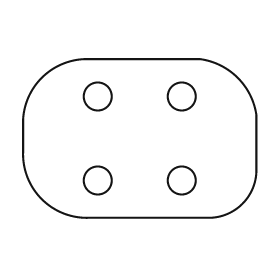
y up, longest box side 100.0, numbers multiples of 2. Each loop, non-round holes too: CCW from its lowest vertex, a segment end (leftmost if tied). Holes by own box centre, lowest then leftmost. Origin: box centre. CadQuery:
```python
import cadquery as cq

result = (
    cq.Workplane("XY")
    .moveTo(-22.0, -34.0)
    .lineTo(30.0, -34.0)
    .threePointArc((44.0, -28.0), (50.0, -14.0))
    .lineTo(50.0, 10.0)
    .threePointArc((42.0, 26.0), (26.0, 34.0))
    .lineTo(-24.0, 34.0)
    .threePointArc((-42.0, 26.0), (-50.0, 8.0))
    .lineTo(-50.0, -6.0)
    .threePointArc((-42.0, -26.0), (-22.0, -34.0))
    .close()
    .moveTo(-18.0, -18.0)
    .circle(6.0)
    .moveTo(18.0, -18.0)
    .circle(6.0)
    .moveTo(-18.0, 18.0)
    .circle(6.0)
    .moveTo(18.0, 18.0)
    .circle(6.0)
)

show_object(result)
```